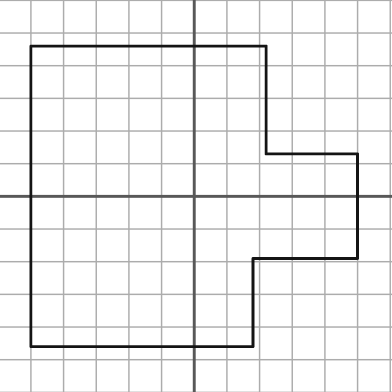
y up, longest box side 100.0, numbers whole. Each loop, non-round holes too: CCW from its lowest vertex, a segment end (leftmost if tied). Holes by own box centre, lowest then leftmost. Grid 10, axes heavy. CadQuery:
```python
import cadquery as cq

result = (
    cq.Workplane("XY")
    .moveTo(-50.0, -46.0)
    .lineTo(18.0, -46.0)
    .lineTo(18.0, -19.0)
    .lineTo(50.0, -19.0)
    .lineTo(50.0, 13.0)
    .lineTo(22.0, 13.0)
    .lineTo(22.0, 46.0)
    .lineTo(-50.0, 46.0)
    .close()
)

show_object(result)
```